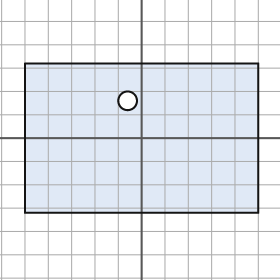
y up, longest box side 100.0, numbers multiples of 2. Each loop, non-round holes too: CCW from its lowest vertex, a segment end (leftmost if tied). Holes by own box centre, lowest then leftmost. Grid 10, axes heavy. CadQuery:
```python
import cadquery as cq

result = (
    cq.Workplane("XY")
    .moveTo(-50.0, -32.0)
    .lineTo(50.0, -32.0)
    .lineTo(50.0, 32.0)
    .lineTo(-50.0, 32.0)
    .close()
    .moveTo(-6.0, 16.0)
    .circle(4.0)
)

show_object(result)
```